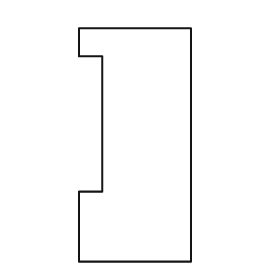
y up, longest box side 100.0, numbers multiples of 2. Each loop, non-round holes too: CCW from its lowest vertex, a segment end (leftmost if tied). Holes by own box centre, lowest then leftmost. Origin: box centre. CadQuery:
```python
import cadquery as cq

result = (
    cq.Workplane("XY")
    .moveTo(-24.0, -50.0)
    .lineTo(24.0, -50.0)
    .lineTo(24.0, 50.0)
    .lineTo(-24.0, 50.0)
    .lineTo(-24.0, 38.0)
    .lineTo(-14.0, 38.0)
    .lineTo(-14.0, -20.0)
    .lineTo(-24.0, -20.0)
    .close()
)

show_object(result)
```